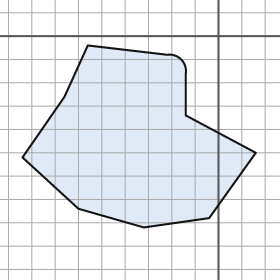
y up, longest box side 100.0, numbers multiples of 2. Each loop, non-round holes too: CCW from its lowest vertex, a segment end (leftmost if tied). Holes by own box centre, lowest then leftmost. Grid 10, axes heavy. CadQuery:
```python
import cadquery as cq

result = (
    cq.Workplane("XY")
    .moveTo(-32.0, -82.0)
    .lineTo(-4.0, -78.0)
    .lineTo(16.0, -50.0)
    .lineTo(-14.0, -34.0)
    .lineTo(-14.0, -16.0)
    .threePointArc((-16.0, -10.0), (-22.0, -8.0))
    .lineTo(-56.0, -4.0)
    .lineTo(-66.0, -26.0)
    .lineTo(-84.0, -52.0)
    .lineTo(-60.0, -74.0)
    .close()
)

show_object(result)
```